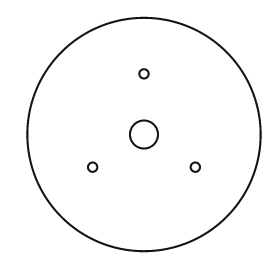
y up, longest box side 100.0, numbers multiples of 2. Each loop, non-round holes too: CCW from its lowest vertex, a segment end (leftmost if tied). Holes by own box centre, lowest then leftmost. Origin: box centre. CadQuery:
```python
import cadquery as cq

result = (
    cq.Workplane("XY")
    .moveTo(0.0, 0.0)
    .circle(50.0)
    .moveTo(-22.0, -14.0)
    .circle(2.0)
    .moveTo(22.0, -14.0)
    .circle(2.0)
    .moveTo(0.0, 0.0)
    .circle(6.0)
    .moveTo(0.0, 26.0)
    .circle(2.0)
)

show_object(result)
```